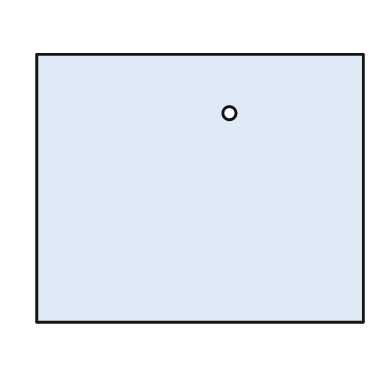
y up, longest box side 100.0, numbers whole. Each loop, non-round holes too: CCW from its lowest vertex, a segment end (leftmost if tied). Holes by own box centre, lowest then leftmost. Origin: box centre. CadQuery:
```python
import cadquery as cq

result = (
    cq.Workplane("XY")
    .moveTo(-50.0, -41.0)
    .lineTo(50.0, -41.0)
    .lineTo(50.0, 41.0)
    .lineTo(-50.0, 41.0)
    .close()
    .moveTo(9.0, 23.0)
    .circle(2.0)
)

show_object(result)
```